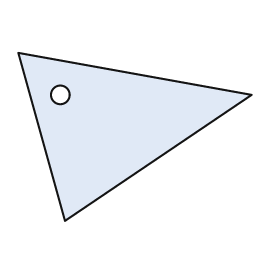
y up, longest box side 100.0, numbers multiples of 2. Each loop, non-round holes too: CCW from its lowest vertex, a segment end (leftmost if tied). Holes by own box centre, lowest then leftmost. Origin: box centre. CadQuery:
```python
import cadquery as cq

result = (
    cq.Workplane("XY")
    .moveTo(-30.0, -36.0)
    .lineTo(50.0, 18.0)
    .lineTo(-50.0, 36.0)
    .close()
    .moveTo(-32.0, 18.0)
    .circle(4.0)
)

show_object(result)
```